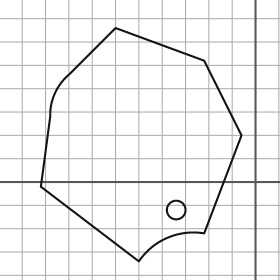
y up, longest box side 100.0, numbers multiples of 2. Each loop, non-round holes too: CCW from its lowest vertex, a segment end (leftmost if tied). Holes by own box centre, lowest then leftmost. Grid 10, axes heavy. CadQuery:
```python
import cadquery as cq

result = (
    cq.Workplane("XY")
    .moveTo(-50.0, -34.0)
    .threePointArc((-38.0, -24.0), (-22.0, -22.0))
    .lineTo(-6.0, 20.0)
    .lineTo(-22.0, 52.0)
    .lineTo(-60.0, 66.0)
    .lineTo(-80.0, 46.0)
    .threePointArc((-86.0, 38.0), (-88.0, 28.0))
    .lineTo(-92.0, -2.0)
    .close()
    .moveTo(-34.0, -12.0)
    .circle(4.0)
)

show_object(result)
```